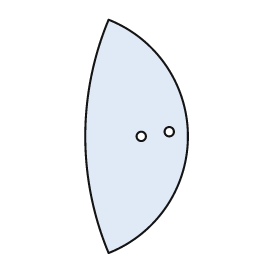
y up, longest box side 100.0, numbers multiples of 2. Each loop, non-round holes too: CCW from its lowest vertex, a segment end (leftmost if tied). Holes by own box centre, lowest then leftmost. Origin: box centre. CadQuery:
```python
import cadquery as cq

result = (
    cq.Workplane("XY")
    .moveTo(-12.0, -50.0)
    .threePointArc((22.0, 0.0), (-12.0, 50.0))
    .threePointArc((-22.0, 0.0), (-12.0, -50.0))
    .close()
    .moveTo(2.0, 0.0)
    .circle(2.0)
    .moveTo(14.0, 2.0)
    .circle(2.0)
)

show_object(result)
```